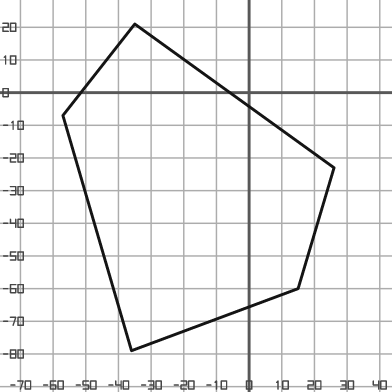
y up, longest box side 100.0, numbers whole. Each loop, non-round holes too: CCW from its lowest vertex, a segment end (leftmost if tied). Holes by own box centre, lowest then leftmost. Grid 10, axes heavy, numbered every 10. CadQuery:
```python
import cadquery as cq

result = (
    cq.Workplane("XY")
    .moveTo(-36.0, -79.0)
    .lineTo(15.0, -60.0)
    .lineTo(26.0, -23.0)
    .lineTo(-35.0, 21.0)
    .lineTo(-57.0, -7.0)
    .close()
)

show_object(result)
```